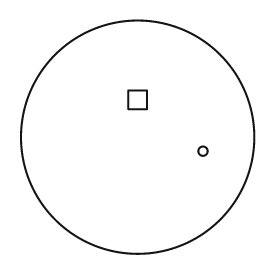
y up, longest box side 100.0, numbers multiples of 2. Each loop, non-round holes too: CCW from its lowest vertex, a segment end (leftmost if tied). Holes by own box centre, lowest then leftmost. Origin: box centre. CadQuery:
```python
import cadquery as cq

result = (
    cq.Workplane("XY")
    .moveTo(0.0, 0.0)
    .circle(50.0)
    .moveTo(28.0, -6.0)
    .circle(2.0)
    .moveTo(-4.0, 12.0)
    .lineTo(4.0, 12.0)
    .lineTo(4.0, 20.0)
    .lineTo(-4.0, 20.0)
    .close()
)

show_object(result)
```